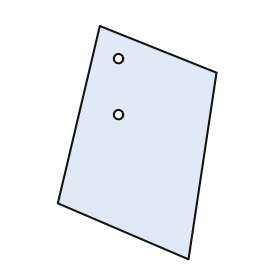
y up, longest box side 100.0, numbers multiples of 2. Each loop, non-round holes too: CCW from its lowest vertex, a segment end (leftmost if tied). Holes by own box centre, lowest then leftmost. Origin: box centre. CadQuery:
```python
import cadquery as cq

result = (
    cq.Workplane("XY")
    .moveTo(22.0, -50.0)
    .lineTo(34.0, 30.0)
    .lineTo(-16.0, 50.0)
    .lineTo(-34.0, -26.0)
    .close()
    .moveTo(-8.0, 12.0)
    .circle(2.0)
    .moveTo(-8.0, 36.0)
    .circle(2.0)
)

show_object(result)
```